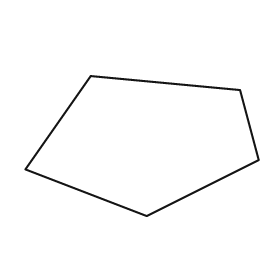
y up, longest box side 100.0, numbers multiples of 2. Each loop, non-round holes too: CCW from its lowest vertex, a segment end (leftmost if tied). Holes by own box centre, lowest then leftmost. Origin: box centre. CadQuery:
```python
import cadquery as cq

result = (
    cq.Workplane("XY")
    .moveTo(2.0, -30.0)
    .lineTo(50.0, -6.0)
    .lineTo(42.0, 24.0)
    .lineTo(-22.0, 30.0)
    .lineTo(-50.0, -10.0)
    .close()
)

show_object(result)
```